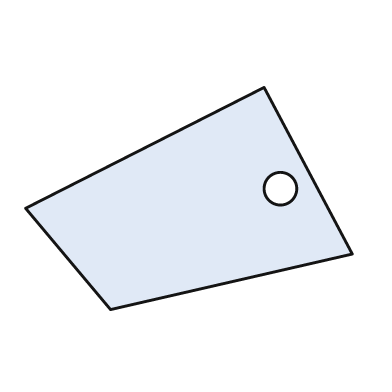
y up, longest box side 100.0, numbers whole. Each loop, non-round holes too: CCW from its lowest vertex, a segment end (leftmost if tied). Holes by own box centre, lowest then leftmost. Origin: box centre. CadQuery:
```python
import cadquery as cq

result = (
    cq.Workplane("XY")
    .moveTo(-24.0, -34.0)
    .lineTo(50.0, -17.0)
    .lineTo(23.0, 34.0)
    .lineTo(-50.0, -3.0)
    .close()
    .moveTo(28.0, 3.0)
    .circle(5.0)
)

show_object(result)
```